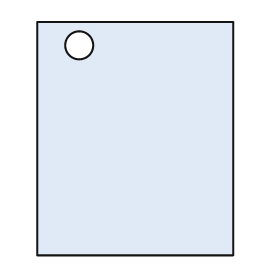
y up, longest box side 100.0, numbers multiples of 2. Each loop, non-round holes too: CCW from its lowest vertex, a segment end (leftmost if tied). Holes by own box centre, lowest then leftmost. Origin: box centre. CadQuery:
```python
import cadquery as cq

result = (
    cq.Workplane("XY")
    .moveTo(-42.0, -50.0)
    .lineTo(42.0, -50.0)
    .lineTo(42.0, 50.0)
    .lineTo(-42.0, 50.0)
    .close()
    .moveTo(-24.0, 40.0)
    .circle(6.0)
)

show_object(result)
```